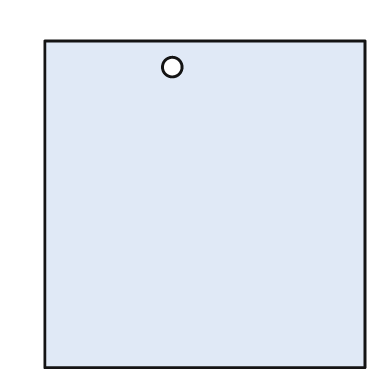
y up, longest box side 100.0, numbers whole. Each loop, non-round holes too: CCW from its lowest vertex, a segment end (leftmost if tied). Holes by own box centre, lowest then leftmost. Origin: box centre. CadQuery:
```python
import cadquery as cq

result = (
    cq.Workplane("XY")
    .moveTo(-49.0, -50.0)
    .lineTo(49.0, -50.0)
    .lineTo(49.0, 50.0)
    .lineTo(-49.0, 50.0)
    .close()
    .moveTo(-10.0, 42.0)
    .circle(3.0)
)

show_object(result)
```